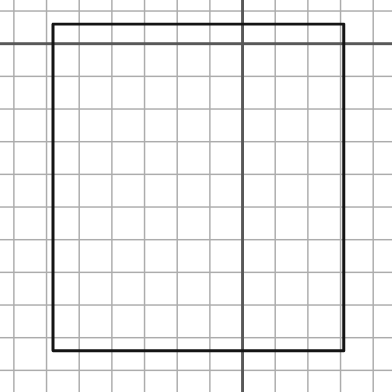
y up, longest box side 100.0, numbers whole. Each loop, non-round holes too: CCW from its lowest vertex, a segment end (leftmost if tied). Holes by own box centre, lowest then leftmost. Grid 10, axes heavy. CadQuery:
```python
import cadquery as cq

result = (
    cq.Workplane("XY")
    .moveTo(-58.0, -94.0)
    .lineTo(31.0, -94.0)
    .lineTo(31.0, 6.0)
    .lineTo(-58.0, 6.0)
    .close()
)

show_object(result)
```